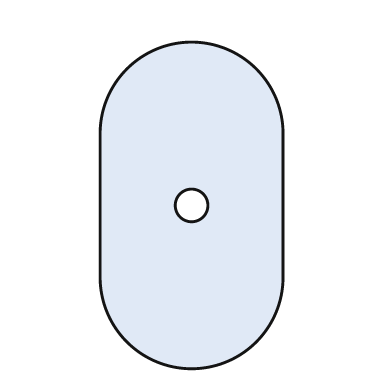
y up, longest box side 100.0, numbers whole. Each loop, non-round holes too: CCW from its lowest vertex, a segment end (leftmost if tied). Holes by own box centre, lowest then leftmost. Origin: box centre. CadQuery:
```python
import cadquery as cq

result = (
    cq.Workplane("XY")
    .moveTo(-28.0, -22.0)
    .threePointArc((0.0, -50.0), (28.0, -22.0))
    .lineTo(28.0, 22.0)
    .threePointArc((0.0, 50.0), (-28.0, 22.0))
    .close()
    .moveTo(0.0, 0.0)
    .circle(5.0)
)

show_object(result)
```